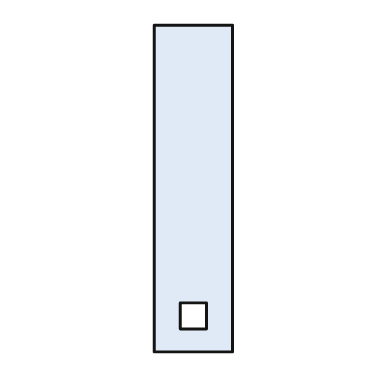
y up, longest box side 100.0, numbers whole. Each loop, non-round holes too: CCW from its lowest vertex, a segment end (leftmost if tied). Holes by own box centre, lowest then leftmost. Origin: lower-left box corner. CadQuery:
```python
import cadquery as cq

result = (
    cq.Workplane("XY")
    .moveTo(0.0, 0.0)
    .lineTo(24.0, 0.0)
    .lineTo(24.0, 100.0)
    .lineTo(0.0, 100.0)
    .close()
    .moveTo(8.0, 7.0)
    .lineTo(16.0, 7.0)
    .lineTo(16.0, 15.0)
    .lineTo(8.0, 15.0)
    .close()
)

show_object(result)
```